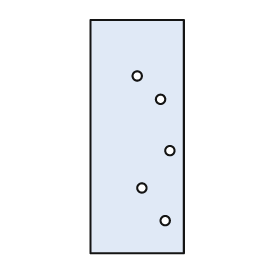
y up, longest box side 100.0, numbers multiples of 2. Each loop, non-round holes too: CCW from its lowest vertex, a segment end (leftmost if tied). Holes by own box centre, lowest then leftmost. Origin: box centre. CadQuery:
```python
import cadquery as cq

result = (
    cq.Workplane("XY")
    .moveTo(-20.0, -50.0)
    .lineTo(20.0, -50.0)
    .lineTo(20.0, 50.0)
    .lineTo(-20.0, 50.0)
    .close()
    .moveTo(12.0, -36.0)
    .circle(2.0)
    .moveTo(2.0, -22.0)
    .circle(2.0)
    .moveTo(14.0, -6.0)
    .circle(2.0)
    .moveTo(10.0, 16.0)
    .circle(2.0)
    .moveTo(0.0, 26.0)
    .circle(2.0)
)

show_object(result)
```